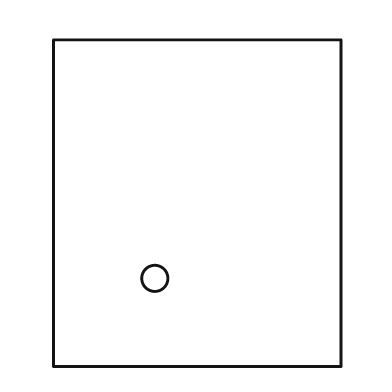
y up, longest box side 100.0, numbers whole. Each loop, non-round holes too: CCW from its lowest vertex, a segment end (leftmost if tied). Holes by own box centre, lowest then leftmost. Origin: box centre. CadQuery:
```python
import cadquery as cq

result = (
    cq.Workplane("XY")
    .moveTo(-44.0, -50.0)
    .lineTo(44.0, -50.0)
    .lineTo(44.0, 50.0)
    .lineTo(-44.0, 50.0)
    .close()
    .moveTo(-13.0, -23.0)
    .circle(4.0)
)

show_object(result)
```